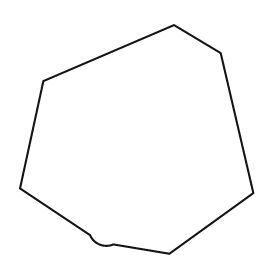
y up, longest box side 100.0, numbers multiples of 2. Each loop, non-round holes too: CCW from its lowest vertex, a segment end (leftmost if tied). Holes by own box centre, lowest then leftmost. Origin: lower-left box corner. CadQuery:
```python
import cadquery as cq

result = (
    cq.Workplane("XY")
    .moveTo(64.0, 0.0)
    .lineTo(100.0, 26.0)
    .lineTo(86.0, 86.0)
    .lineTo(66.0, 98.0)
    .lineTo(10.0, 74.0)
    .lineTo(0.0, 28.0)
    .lineTo(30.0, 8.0)
    .threePointArc((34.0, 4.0), (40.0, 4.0))
    .close()
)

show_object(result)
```